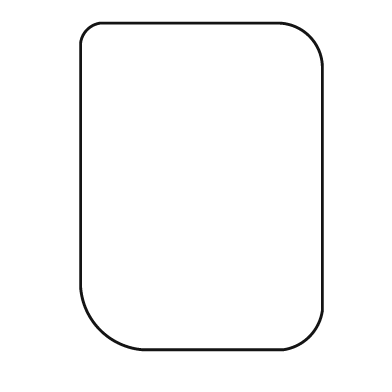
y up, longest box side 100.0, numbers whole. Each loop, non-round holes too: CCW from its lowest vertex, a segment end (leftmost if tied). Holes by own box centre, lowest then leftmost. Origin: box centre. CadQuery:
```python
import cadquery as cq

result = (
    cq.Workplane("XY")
    .moveTo(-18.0, -50.0)
    .lineTo(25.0, -50.0)
    .threePointArc((33.0, -46.0), (37.0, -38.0))
    .lineTo(37.0, 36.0)
    .threePointArc((33.0, 46.0), (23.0, 50.0))
    .lineTo(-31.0, 50.0)
    .threePointArc((-35.0, 48.0), (-37.0, 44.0))
    .lineTo(-37.0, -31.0)
    .threePointArc((-31.0, -44.0), (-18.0, -50.0))
    .close()
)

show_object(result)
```